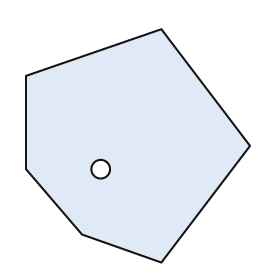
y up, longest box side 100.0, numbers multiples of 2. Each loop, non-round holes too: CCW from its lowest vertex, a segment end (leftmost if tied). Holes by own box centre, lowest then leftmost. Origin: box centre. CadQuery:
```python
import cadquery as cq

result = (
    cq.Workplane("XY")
    .moveTo(10.0, -50.0)
    .lineTo(48.0, 0.0)
    .lineTo(10.0, 50.0)
    .lineTo(-48.0, 30.0)
    .lineTo(-48.0, -10.0)
    .lineTo(-24.0, -38.0)
    .close()
    .moveTo(-16.0, -10.0)
    .circle(4.0)
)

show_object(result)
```